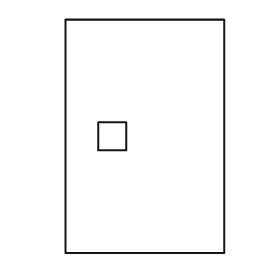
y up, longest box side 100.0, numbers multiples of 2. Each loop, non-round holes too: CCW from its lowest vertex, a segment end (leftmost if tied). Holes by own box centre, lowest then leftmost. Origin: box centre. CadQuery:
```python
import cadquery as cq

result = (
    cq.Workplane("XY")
    .moveTo(-34.0, -50.0)
    .lineTo(34.0, -50.0)
    .lineTo(34.0, 50.0)
    .lineTo(-34.0, 50.0)
    .close()
    .moveTo(-20.0, -6.0)
    .lineTo(-8.0, -6.0)
    .lineTo(-8.0, 6.0)
    .lineTo(-20.0, 6.0)
    .close()
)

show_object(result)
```